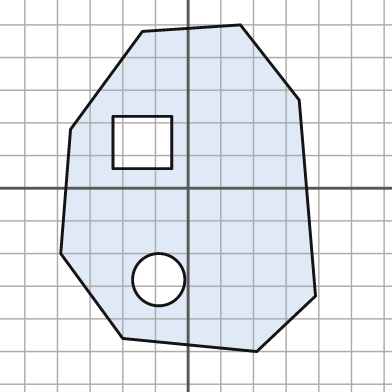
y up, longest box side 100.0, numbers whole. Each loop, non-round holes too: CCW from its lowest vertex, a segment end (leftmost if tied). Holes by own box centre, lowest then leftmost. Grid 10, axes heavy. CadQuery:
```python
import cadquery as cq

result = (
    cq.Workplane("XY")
    .moveTo(21.0, -50.0)
    .lineTo(39.0, -33.0)
    .lineTo(34.0, 27.0)
    .lineTo(16.0, 50.0)
    .lineTo(-14.0, 48.0)
    .lineTo(-36.0, 18.0)
    .lineTo(-39.0, -20.0)
    .lineTo(-20.0, -46.0)
    .close()
    .moveTo(-9.0, -28.0)
    .circle(8.0)
    .moveTo(-23.0, 6.0)
    .lineTo(-5.0, 6.0)
    .lineTo(-5.0, 22.0)
    .lineTo(-23.0, 22.0)
    .close()
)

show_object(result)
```